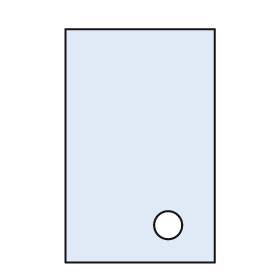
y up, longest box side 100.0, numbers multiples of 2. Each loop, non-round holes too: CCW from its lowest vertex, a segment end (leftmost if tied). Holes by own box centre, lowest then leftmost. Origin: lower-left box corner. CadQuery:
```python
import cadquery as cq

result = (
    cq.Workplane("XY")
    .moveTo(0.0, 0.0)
    .lineTo(64.0, 0.0)
    .lineTo(64.0, 100.0)
    .lineTo(0.0, 100.0)
    .close()
    .moveTo(44.0, 16.0)
    .circle(6.0)
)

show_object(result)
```